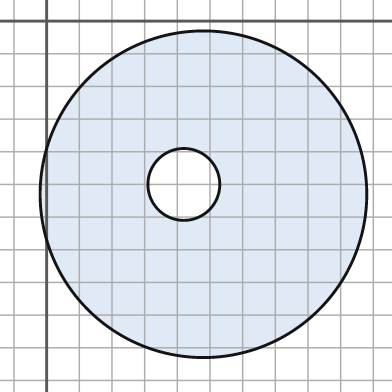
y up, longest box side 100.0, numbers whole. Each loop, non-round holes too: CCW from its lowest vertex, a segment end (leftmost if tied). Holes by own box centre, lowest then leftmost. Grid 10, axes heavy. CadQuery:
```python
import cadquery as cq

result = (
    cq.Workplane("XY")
    .moveTo(48.0, -53.0)
    .circle(50.0)
    .moveTo(42.0, -50.0)
    .circle(11.0)
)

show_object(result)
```